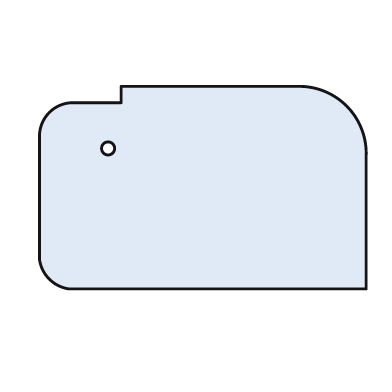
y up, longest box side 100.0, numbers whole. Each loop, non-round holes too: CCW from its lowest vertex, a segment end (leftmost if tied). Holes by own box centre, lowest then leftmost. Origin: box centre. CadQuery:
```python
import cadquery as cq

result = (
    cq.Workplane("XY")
    .moveTo(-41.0, -31.0)
    .lineTo(50.0, -31.0)
    .lineTo(50.0, 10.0)
    .threePointArc((44.0, 25.0), (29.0, 31.0))
    .lineTo(-25.0, 31.0)
    .lineTo(-25.0, 26.0)
    .lineTo(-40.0, 26.0)
    .threePointArc((-47.0, 23.0), (-50.0, 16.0))
    .lineTo(-50.0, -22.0)
    .threePointArc((-47.0, -28.0), (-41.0, -31.0))
    .close()
    .moveTo(-29.0, 12.0)
    .circle(2.0)
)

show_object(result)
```